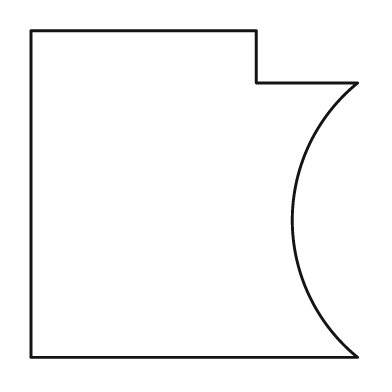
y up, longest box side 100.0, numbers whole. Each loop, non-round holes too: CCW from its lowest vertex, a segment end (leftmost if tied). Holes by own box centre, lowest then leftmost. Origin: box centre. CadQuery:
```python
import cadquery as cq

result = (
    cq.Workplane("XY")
    .moveTo(-50.0, -50.0)
    .lineTo(50.0, -50.0)
    .threePointArc((30.0, -8.0), (50.0, 34.0))
    .lineTo(19.0, 34.0)
    .lineTo(19.0, 50.0)
    .lineTo(-50.0, 50.0)
    .close()
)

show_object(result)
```